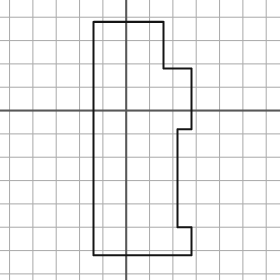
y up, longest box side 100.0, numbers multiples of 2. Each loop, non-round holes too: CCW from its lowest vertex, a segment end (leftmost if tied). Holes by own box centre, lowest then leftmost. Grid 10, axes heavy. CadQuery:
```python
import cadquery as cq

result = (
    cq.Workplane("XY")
    .moveTo(-14.0, -62.0)
    .lineTo(28.0, -62.0)
    .lineTo(28.0, -50.0)
    .lineTo(22.0, -50.0)
    .lineTo(22.0, -8.0)
    .lineTo(28.0, -8.0)
    .lineTo(28.0, 18.0)
    .lineTo(16.0, 18.0)
    .lineTo(16.0, 38.0)
    .lineTo(-14.0, 38.0)
    .close()
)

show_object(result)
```